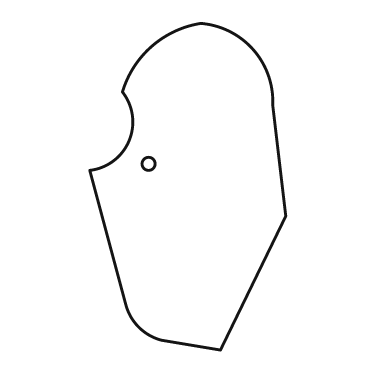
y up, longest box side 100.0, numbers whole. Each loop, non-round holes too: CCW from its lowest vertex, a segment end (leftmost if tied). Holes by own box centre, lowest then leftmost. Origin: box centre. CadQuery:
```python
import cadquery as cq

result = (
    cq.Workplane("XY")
    .moveTo(10.0, -50.0)
    .lineTo(30.0, -9.0)
    .lineTo(26.0, 25.0)
    .threePointArc((20.0, 42.0), (4.0, 50.0))
    .threePointArc((-11.0, 43.0), (-20.0, 29.0))
    .threePointArc((-18.0, 14.0), (-30.0, 5.0))
    .lineTo(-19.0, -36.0)
    .threePointArc((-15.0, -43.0), (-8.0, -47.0))
    .close()
    .moveTo(-12.0, 7.0)
    .circle(2.0)
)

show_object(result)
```